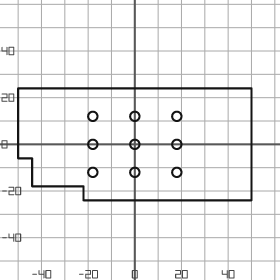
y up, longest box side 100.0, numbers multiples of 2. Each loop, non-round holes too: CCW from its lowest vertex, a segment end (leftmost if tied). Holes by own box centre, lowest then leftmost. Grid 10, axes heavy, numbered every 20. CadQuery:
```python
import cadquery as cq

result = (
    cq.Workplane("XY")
    .moveTo(-22.0, -24.0)
    .lineTo(50.0, -24.0)
    .lineTo(50.0, 24.0)
    .lineTo(-50.0, 24.0)
    .lineTo(-50.0, -6.0)
    .lineTo(-44.0, -6.0)
    .lineTo(-44.0, -18.0)
    .lineTo(-22.0, -18.0)
    .close()
    .moveTo(-18.0, -12.0)
    .circle(2.0)
    .moveTo(0.0, -12.0)
    .circle(2.0)
    .moveTo(18.0, -12.0)
    .circle(2.0)
    .moveTo(-18.0, 0.0)
    .circle(2.0)
    .moveTo(0.0, 0.0)
    .circle(2.0)
    .moveTo(18.0, 0.0)
    .circle(2.0)
    .moveTo(-18.0, 12.0)
    .circle(2.0)
    .moveTo(0.0, 12.0)
    .circle(2.0)
    .moveTo(18.0, 12.0)
    .circle(2.0)
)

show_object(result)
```